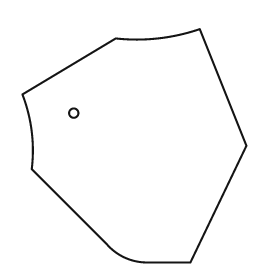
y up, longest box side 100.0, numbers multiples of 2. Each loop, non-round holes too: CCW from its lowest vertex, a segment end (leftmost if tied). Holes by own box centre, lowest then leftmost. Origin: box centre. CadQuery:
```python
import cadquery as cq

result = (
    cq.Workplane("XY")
    .moveTo(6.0, -50.0)
    .lineTo(24.0, -50.0)
    .lineTo(48.0, 0.0)
    .lineTo(28.0, 50.0)
    .threePointArc((10.0, 46.0), (-8.0, 46.0))
    .lineTo(-48.0, 22.0)
    .threePointArc((-44.0, 6.0), (-44.0, -10.0))
    .lineTo(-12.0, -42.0)
    .threePointArc((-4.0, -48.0), (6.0, -50.0))
    .close()
    .moveTo(-26.0, 14.0)
    .circle(2.0)
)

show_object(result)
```